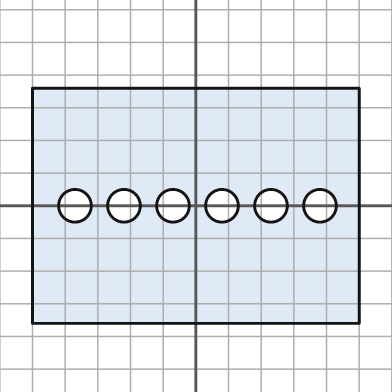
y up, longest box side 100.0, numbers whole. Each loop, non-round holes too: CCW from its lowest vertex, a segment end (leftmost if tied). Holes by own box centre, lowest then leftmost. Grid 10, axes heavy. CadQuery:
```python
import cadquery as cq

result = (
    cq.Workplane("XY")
    .moveTo(-50.0, -36.0)
    .lineTo(50.0, -36.0)
    .lineTo(50.0, 36.0)
    .lineTo(-50.0, 36.0)
    .close()
    .moveTo(-37.0, 0.0)
    .circle(5.0)
    .moveTo(-22.0, 0.0)
    .circle(5.0)
    .moveTo(-7.0, 0.0)
    .circle(5.0)
    .moveTo(8.0, 0.0)
    .circle(5.0)
    .moveTo(23.0, 0.0)
    .circle(5.0)
    .moveTo(38.0, 0.0)
    .circle(5.0)
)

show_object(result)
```